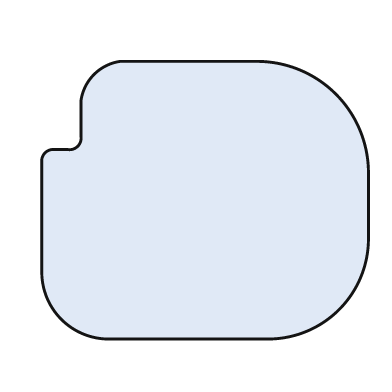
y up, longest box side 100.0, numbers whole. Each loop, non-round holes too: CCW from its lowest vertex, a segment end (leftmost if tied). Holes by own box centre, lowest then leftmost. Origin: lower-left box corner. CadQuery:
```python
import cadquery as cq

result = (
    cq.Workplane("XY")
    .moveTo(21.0, 0.0)
    .lineTo(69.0, 0.0)
    .threePointArc((91.0, 9.0), (100.0, 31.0))
    .lineTo(100.0, 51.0)
    .threePointArc((90.0, 75.0), (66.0, 85.0))
    .lineTo(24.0, 85.0)
    .threePointArc((16.0, 81.0), (12.0, 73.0))
    .lineTo(12.0, 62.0)
    .threePointArc((11.0, 59.0), (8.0, 58.0))
    .lineTo(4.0, 58.0)
    .threePointArc((1.0, 57.0), (0.0, 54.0))
    .lineTo(0.0, 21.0)
    .threePointArc((6.0, 6.0), (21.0, 0.0))
    .close()
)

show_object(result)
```